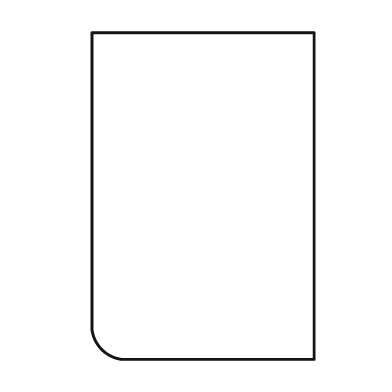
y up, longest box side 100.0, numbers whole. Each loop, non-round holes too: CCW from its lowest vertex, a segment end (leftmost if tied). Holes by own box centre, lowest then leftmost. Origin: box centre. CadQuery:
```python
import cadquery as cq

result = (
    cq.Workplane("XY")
    .moveTo(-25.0, -50.0)
    .lineTo(34.0, -50.0)
    .lineTo(34.0, 50.0)
    .lineTo(-34.0, 50.0)
    .lineTo(-34.0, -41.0)
    .threePointArc((-31.0, -47.0), (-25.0, -50.0))
    .close()
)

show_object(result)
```